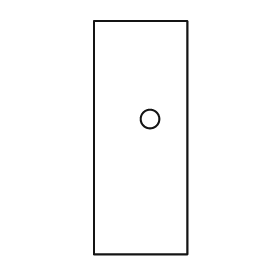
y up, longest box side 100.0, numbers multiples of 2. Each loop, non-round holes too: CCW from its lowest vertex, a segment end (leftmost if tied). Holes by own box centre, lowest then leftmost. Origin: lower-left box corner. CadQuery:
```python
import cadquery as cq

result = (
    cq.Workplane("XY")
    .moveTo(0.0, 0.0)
    .lineTo(40.0, 0.0)
    .lineTo(40.0, 100.0)
    .lineTo(0.0, 100.0)
    .close()
    .moveTo(24.0, 58.0)
    .circle(4.0)
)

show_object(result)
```